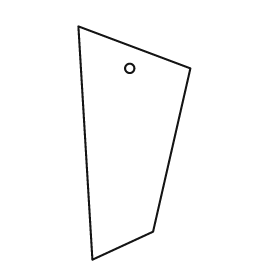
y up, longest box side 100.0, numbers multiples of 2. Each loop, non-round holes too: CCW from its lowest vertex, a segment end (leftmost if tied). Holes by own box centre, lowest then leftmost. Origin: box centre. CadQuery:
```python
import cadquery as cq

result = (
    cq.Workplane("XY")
    .moveTo(-18.0, -50.0)
    .lineTo(8.0, -38.0)
    .lineTo(24.0, 32.0)
    .lineTo(-24.0, 50.0)
    .close()
    .moveTo(-2.0, 32.0)
    .circle(2.0)
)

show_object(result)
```